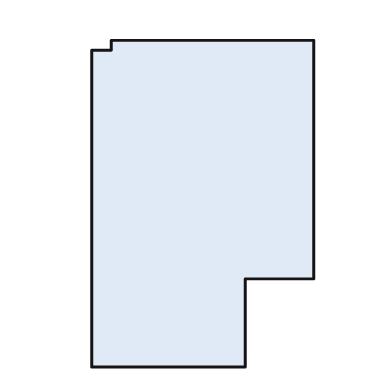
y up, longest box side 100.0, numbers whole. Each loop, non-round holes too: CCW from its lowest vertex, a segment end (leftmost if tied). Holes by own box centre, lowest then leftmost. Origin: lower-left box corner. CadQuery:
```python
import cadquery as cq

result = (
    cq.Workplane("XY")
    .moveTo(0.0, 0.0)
    .lineTo(47.0, 0.0)
    .lineTo(47.0, 27.0)
    .lineTo(68.0, 27.0)
    .lineTo(68.0, 100.0)
    .lineTo(6.0, 100.0)
    .lineTo(6.0, 97.0)
    .lineTo(0.0, 97.0)
    .close()
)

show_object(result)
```